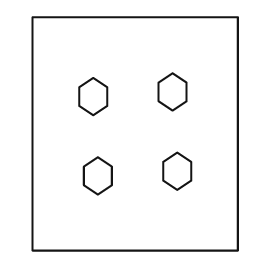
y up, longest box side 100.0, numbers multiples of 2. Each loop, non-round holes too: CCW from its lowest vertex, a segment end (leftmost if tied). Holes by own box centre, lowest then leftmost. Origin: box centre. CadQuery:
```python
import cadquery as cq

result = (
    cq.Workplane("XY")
    .moveTo(-44.0, -50.0)
    .lineTo(44.0, -50.0)
    .lineTo(44.0, 50.0)
    .lineTo(-44.0, 50.0)
    .close()
    .moveTo(-16.0, -26.0)
    .lineTo(-10.0, -22.0)
    .lineTo(-10.0, -14.0)
    .lineTo(-16.0, -10.0)
    .lineTo(-22.0, -14.0)
    .lineTo(-22.0, -22.0)
    .close()
    .moveTo(18.0, -24.0)
    .lineTo(24.0, -20.0)
    .lineTo(24.0, -12.0)
    .lineTo(18.0, -8.0)
    .lineTo(12.0, -12.0)
    .lineTo(12.0, -20.0)
    .close()
    .moveTo(-18.0, 8.0)
    .lineTo(-12.0, 12.0)
    .lineTo(-12.0, 20.0)
    .lineTo(-18.0, 24.0)
    .lineTo(-24.0, 20.0)
    .lineTo(-24.0, 12.0)
    .close()
    .moveTo(16.0, 10.0)
    .lineTo(22.0, 14.0)
    .lineTo(22.0, 22.0)
    .lineTo(16.0, 26.0)
    .lineTo(10.0, 22.0)
    .lineTo(10.0, 14.0)
    .close()
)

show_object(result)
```